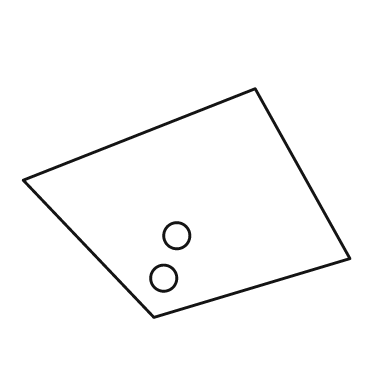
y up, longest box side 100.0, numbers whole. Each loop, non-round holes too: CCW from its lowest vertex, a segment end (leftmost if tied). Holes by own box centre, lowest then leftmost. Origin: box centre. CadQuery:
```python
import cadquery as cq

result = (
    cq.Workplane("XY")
    .moveTo(-10.0, -35.0)
    .lineTo(50.0, -17.0)
    .lineTo(21.0, 35.0)
    .lineTo(-50.0, 7.0)
    .close()
    .moveTo(-7.0, -23.0)
    .circle(4.0)
    .moveTo(-3.0, -10.0)
    .circle(4.0)
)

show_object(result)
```